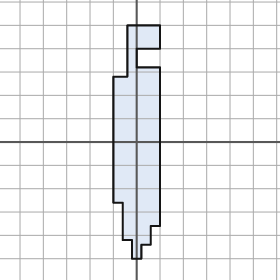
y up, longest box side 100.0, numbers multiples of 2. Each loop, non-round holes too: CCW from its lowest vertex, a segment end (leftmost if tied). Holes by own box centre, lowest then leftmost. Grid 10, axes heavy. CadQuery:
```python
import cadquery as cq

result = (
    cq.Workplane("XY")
    .moveTo(-2.0, -50.0)
    .lineTo(2.0, -50.0)
    .lineTo(2.0, -44.0)
    .lineTo(6.0, -44.0)
    .lineTo(6.0, -36.0)
    .lineTo(10.0, -36.0)
    .lineTo(10.0, 32.0)
    .lineTo(0.0, 32.0)
    .lineTo(0.0, 40.0)
    .lineTo(10.0, 40.0)
    .lineTo(10.0, 50.0)
    .lineTo(-4.0, 50.0)
    .lineTo(-4.0, 28.0)
    .lineTo(-10.0, 28.0)
    .lineTo(-10.0, -26.0)
    .lineTo(-6.0, -26.0)
    .lineTo(-6.0, -42.0)
    .lineTo(-2.0, -42.0)
    .close()
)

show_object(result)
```